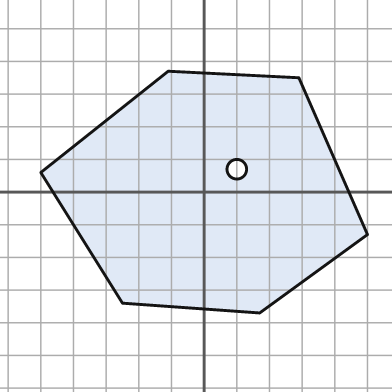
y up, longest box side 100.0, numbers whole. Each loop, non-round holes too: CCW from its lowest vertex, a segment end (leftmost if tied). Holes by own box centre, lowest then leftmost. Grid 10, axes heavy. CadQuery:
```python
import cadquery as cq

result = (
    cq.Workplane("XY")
    .moveTo(17.0, -37.0)
    .lineTo(50.0, -13.0)
    .lineTo(29.0, 35.0)
    .lineTo(-11.0, 37.0)
    .lineTo(-50.0, 6.0)
    .lineTo(-25.0, -34.0)
    .close()
    .moveTo(10.0, 7.0)
    .circle(3.0)
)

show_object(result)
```